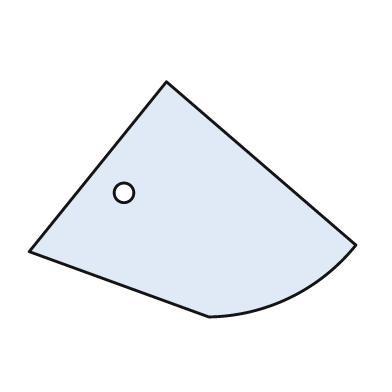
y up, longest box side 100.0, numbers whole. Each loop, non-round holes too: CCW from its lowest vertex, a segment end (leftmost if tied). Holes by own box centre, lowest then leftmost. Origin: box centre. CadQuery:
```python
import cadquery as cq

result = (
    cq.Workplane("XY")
    .moveTo(5.0, -36.0)
    .threePointArc((30.0, -30.0), (50.0, -14.0))
    .lineTo(-8.0, 36.0)
    .lineTo(-50.0, -16.0)
    .close()
    .moveTo(-21.0, 2.0)
    .circle(3.0)
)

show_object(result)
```